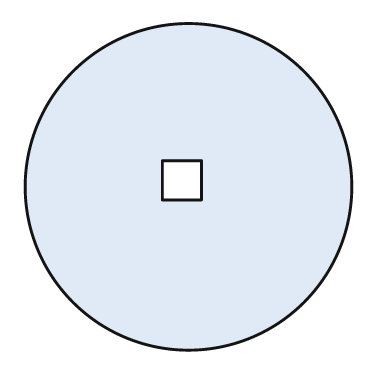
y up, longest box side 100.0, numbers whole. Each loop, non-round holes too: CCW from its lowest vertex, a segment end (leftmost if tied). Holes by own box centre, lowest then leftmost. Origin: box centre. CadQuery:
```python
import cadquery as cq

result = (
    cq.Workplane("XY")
    .moveTo(0.0, 0.0)
    .circle(50.0)
    .moveTo(-8.0, -4.0)
    .lineTo(4.0, -4.0)
    .lineTo(4.0, 8.0)
    .lineTo(-8.0, 8.0)
    .close()
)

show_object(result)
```